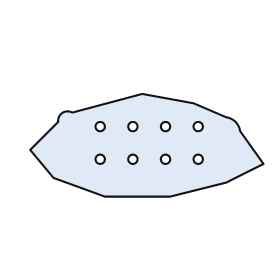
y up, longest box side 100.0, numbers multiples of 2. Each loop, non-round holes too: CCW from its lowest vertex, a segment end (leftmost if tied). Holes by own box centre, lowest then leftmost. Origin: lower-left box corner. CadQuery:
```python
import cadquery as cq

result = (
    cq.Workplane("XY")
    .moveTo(32.0, 0.0)
    .lineTo(60.0, 0.0)
    .lineTo(84.0, 6.0)
    .lineTo(100.0, 14.0)
    .lineTo(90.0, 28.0)
    .threePointArc((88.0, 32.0), (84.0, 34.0))
    .lineTo(70.0, 40.0)
    .lineTo(48.0, 44.0)
    .lineTo(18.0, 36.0)
    .threePointArc((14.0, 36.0), (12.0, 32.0))
    .lineTo(0.0, 20.0)
    .lineTo(10.0, 8.0)
    .close()
    .moveTo(30.0, 16.0)
    .circle(2.0)
    .moveTo(44.0, 16.0)
    .circle(2.0)
    .moveTo(58.0, 16.0)
    .circle(2.0)
    .moveTo(72.0, 16.0)
    .circle(2.0)
    .moveTo(30.0, 30.0)
    .circle(2.0)
    .moveTo(44.0, 30.0)
    .circle(2.0)
    .moveTo(58.0, 30.0)
    .circle(2.0)
    .moveTo(72.0, 30.0)
    .circle(2.0)
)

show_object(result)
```